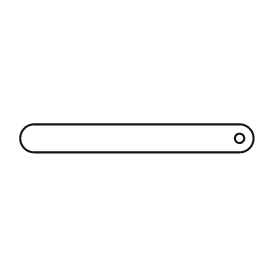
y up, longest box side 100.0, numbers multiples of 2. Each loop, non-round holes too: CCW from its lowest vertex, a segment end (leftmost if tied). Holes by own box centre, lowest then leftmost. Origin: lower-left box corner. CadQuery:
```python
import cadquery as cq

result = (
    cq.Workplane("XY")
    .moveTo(6.0, 0.0)
    .lineTo(94.0, 0.0)
    .threePointArc((100.0, 6.0), (94.0, 12.0))
    .lineTo(6.0, 12.0)
    .threePointArc((0.0, 6.0), (6.0, 0.0))
    .close()
    .moveTo(94.0, 6.0)
    .circle(2.0)
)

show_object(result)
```